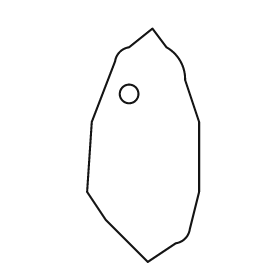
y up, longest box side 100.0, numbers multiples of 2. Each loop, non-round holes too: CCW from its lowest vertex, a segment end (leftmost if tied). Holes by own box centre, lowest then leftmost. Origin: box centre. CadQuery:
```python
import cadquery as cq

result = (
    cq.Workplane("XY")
    .moveTo(2.0, -50.0)
    .lineTo(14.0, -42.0)
    .threePointArc((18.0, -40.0), (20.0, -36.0))
    .lineTo(24.0, -20.0)
    .lineTo(24.0, 10.0)
    .lineTo(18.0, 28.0)
    .threePointArc((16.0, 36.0), (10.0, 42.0))
    .lineTo(4.0, 50.0)
    .lineTo(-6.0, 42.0)
    .threePointArc((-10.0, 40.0), (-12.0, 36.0))
    .lineTo(-22.0, 10.0)
    .lineTo(-24.0, -20.0)
    .lineTo(-16.0, -32.0)
    .close()
    .moveTo(-6.0, 22.0)
    .circle(4.0)
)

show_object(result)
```